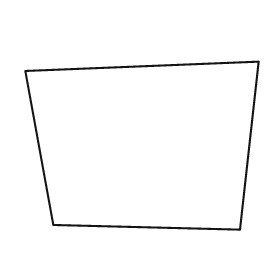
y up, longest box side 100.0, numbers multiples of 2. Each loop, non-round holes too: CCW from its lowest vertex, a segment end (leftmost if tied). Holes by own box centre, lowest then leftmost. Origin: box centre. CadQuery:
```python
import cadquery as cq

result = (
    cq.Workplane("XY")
    .moveTo(42.0, -36.0)
    .lineTo(50.0, 36.0)
    .lineTo(-50.0, 32.0)
    .lineTo(-38.0, -34.0)
    .close()
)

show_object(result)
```